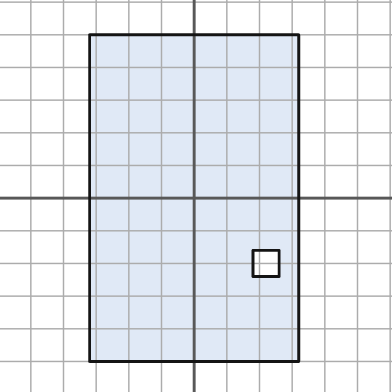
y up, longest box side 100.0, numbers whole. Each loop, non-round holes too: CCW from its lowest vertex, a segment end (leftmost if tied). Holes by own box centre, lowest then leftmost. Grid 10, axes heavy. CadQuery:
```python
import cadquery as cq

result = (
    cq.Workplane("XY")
    .moveTo(-32.0, -50.0)
    .lineTo(32.0, -50.0)
    .lineTo(32.0, 50.0)
    .lineTo(-32.0, 50.0)
    .close()
    .moveTo(18.0, -24.0)
    .lineTo(26.0, -24.0)
    .lineTo(26.0, -16.0)
    .lineTo(18.0, -16.0)
    .close()
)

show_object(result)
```